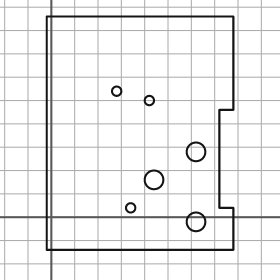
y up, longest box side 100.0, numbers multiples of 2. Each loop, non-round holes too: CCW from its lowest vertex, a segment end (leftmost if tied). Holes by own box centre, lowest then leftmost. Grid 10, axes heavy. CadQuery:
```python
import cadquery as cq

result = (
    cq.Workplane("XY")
    .moveTo(-2.0, -14.0)
    .lineTo(78.0, -14.0)
    .lineTo(78.0, 4.0)
    .lineTo(72.0, 4.0)
    .lineTo(72.0, 46.0)
    .lineTo(78.0, 46.0)
    .lineTo(78.0, 86.0)
    .lineTo(-2.0, 86.0)
    .close()
    .moveTo(62.0, -2.0)
    .circle(4.0)
    .moveTo(34.0, 4.0)
    .circle(2.0)
    .moveTo(44.0, 16.0)
    .circle(4.0)
    .moveTo(62.0, 28.0)
    .circle(4.0)
    .moveTo(42.0, 50.0)
    .circle(2.0)
    .moveTo(28.0, 54.0)
    .circle(2.0)
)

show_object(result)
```